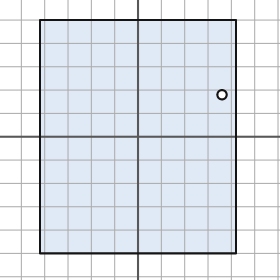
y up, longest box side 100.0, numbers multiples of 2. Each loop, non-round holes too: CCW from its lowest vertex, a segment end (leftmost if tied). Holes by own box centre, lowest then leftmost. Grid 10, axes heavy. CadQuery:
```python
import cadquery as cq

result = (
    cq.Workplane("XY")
    .moveTo(-42.0, -50.0)
    .lineTo(42.0, -50.0)
    .lineTo(42.0, 50.0)
    .lineTo(-42.0, 50.0)
    .close()
    .moveTo(36.0, 18.0)
    .circle(2.0)
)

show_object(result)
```